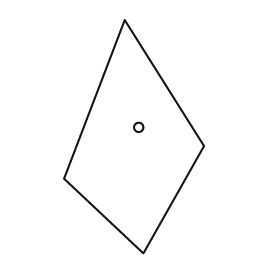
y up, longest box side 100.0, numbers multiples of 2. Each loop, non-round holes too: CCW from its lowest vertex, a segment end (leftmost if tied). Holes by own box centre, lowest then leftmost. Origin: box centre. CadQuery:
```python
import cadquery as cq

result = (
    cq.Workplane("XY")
    .moveTo(4.0, -50.0)
    .lineTo(30.0, -4.0)
    .lineTo(-4.0, 50.0)
    .lineTo(-30.0, -18.0)
    .close()
    .moveTo(2.0, 4.0)
    .circle(2.0)
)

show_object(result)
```